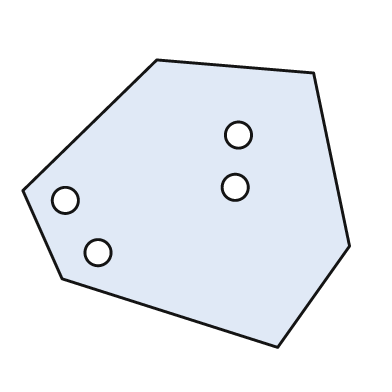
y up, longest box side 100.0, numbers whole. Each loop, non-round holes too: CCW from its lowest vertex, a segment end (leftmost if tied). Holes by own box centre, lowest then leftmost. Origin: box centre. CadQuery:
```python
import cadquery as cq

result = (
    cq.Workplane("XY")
    .moveTo(28.0, -44.0)
    .lineTo(50.0, -13.0)
    .lineTo(39.0, 40.0)
    .lineTo(-9.0, 44.0)
    .lineTo(-50.0, 4.0)
    .lineTo(-38.0, -23.0)
    .close()
    .moveTo(-27.0, -15.0)
    .circle(4.0)
    .moveTo(-37.0, 1.0)
    .circle(4.0)
    .moveTo(15.0, 5.0)
    .circle(4.0)
    .moveTo(16.0, 21.0)
    .circle(4.0)
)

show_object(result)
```